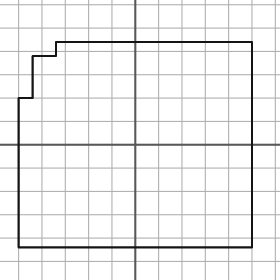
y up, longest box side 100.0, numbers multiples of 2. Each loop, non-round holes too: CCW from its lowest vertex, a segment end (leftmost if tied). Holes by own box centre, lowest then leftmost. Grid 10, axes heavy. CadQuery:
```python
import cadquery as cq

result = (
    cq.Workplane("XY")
    .moveTo(-50.0, -44.0)
    .lineTo(50.0, -44.0)
    .lineTo(50.0, 44.0)
    .lineTo(-34.0, 44.0)
    .lineTo(-34.0, 38.0)
    .lineTo(-44.0, 38.0)
    .lineTo(-44.0, 20.0)
    .lineTo(-50.0, 20.0)
    .close()
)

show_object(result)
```